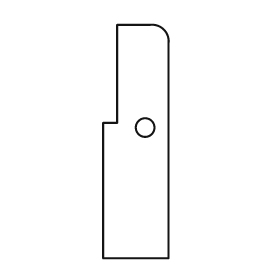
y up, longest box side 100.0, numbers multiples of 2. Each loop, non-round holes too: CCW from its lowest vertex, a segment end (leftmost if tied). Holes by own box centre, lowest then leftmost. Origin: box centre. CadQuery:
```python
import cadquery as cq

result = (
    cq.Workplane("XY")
    .moveTo(-14.0, -50.0)
    .lineTo(14.0, -50.0)
    .lineTo(14.0, 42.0)
    .threePointArc((12.0, 48.0), (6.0, 50.0))
    .lineTo(-8.0, 50.0)
    .lineTo(-8.0, 8.0)
    .lineTo(-14.0, 8.0)
    .close()
    .moveTo(4.0, 6.0)
    .circle(4.0)
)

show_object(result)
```